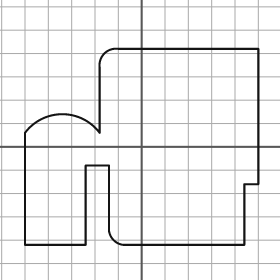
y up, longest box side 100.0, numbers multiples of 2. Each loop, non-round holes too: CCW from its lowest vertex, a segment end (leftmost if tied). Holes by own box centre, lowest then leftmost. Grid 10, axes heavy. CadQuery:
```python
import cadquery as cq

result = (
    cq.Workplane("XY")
    .moveTo(-50.0, -42.0)
    .lineTo(-24.0, -42.0)
    .lineTo(-24.0, -8.0)
    .lineTo(-14.0, -8.0)
    .lineTo(-14.0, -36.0)
    .threePointArc((-12.0, -40.0), (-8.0, -42.0))
    .lineTo(44.0, -42.0)
    .lineTo(44.0, -16.0)
    .lineTo(50.0, -16.0)
    .lineTo(50.0, 42.0)
    .lineTo(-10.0, 42.0)
    .threePointArc((-16.0, 40.0), (-18.0, 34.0))
    .lineTo(-18.0, 6.0)
    .threePointArc((-34.0, 14.0), (-50.0, 6.0))
    .close()
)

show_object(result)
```